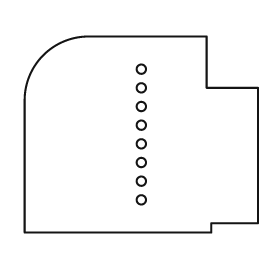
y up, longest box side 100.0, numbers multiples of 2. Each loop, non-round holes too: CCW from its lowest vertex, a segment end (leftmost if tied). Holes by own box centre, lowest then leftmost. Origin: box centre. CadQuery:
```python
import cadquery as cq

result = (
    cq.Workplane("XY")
    .moveTo(-50.0, -42.0)
    .lineTo(30.0, -42.0)
    .lineTo(30.0, -38.0)
    .lineTo(50.0, -38.0)
    .lineTo(50.0, 20.0)
    .lineTo(28.0, 20.0)
    .lineTo(28.0, 42.0)
    .lineTo(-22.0, 42.0)
    .threePointArc((-42.0, 34.0), (-50.0, 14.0))
    .close()
    .moveTo(0.0, -28.0)
    .circle(2.0)
    .moveTo(0.0, -20.0)
    .circle(2.0)
    .moveTo(0.0, -12.0)
    .circle(2.0)
    .moveTo(0.0, -4.0)
    .circle(2.0)
    .moveTo(0.0, 4.0)
    .circle(2.0)
    .moveTo(0.0, 12.0)
    .circle(2.0)
    .moveTo(0.0, 20.0)
    .circle(2.0)
    .moveTo(0.0, 28.0)
    .circle(2.0)
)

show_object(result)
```